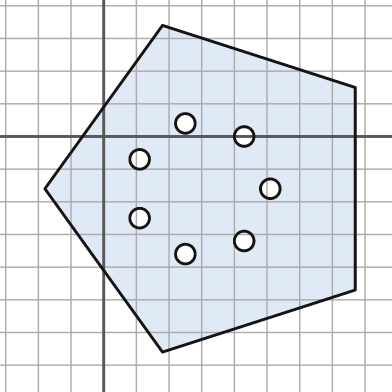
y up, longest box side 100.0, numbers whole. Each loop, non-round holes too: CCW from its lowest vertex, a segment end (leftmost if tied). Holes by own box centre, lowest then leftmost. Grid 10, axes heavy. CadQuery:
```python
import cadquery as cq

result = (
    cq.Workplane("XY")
    .moveTo(18.0, -66.0)
    .lineTo(77.0, -47.0)
    .lineTo(77.0, 15.0)
    .lineTo(18.0, 34.0)
    .lineTo(-18.0, -16.0)
    .close()
    .moveTo(25.0, -36.0)
    .circle(3.0)
    .moveTo(43.0, -32.0)
    .circle(3.0)
    .moveTo(11.0, -25.0)
    .circle(3.0)
    .moveTo(51.0, -16.0)
    .circle(3.0)
    .moveTo(11.0, -7.0)
    .circle(3.0)
    .moveTo(43.0, 0.0)
    .circle(3.0)
    .moveTo(25.0, 4.0)
    .circle(3.0)
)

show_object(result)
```